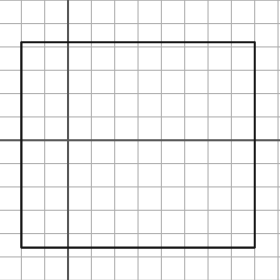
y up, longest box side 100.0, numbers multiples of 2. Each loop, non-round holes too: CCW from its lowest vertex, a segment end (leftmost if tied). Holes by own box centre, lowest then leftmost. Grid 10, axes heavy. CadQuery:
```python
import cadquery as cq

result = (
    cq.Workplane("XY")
    .moveTo(-20.0, -46.0)
    .lineTo(80.0, -46.0)
    .lineTo(80.0, 42.0)
    .lineTo(-20.0, 42.0)
    .close()
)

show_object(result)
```